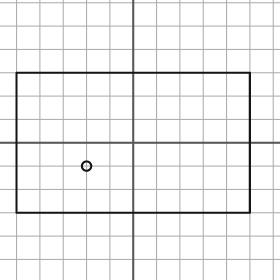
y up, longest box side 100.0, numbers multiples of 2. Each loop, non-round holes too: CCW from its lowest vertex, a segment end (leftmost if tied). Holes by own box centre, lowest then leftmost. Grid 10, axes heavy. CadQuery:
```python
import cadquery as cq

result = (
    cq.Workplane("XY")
    .moveTo(-50.0, -30.0)
    .lineTo(50.0, -30.0)
    .lineTo(50.0, 30.0)
    .lineTo(-50.0, 30.0)
    .close()
    .moveTo(-20.0, -10.0)
    .circle(2.0)
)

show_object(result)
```